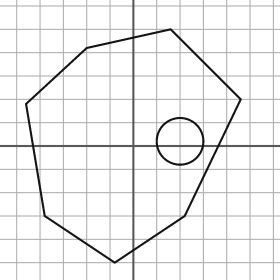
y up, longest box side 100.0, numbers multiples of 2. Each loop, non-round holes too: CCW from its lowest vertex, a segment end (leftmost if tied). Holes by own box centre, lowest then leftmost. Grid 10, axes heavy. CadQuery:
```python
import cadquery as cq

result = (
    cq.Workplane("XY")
    .moveTo(-8.0, -50.0)
    .lineTo(22.0, -30.0)
    .lineTo(46.0, 20.0)
    .lineTo(16.0, 50.0)
    .lineTo(-20.0, 42.0)
    .lineTo(-46.0, 18.0)
    .lineTo(-38.0, -30.0)
    .close()
    .moveTo(20.0, 2.0)
    .circle(10.0)
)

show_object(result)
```